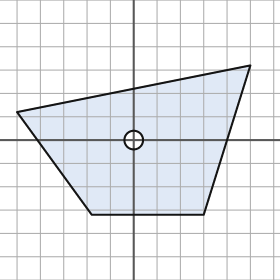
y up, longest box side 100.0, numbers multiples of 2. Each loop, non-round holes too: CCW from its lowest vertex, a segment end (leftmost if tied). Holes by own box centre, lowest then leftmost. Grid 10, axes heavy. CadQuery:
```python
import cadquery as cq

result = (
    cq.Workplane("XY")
    .moveTo(-18.0, -32.0)
    .lineTo(30.0, -32.0)
    .lineTo(50.0, 32.0)
    .lineTo(-50.0, 12.0)
    .close()
    .moveTo(0.0, 0.0)
    .circle(4.0)
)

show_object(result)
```